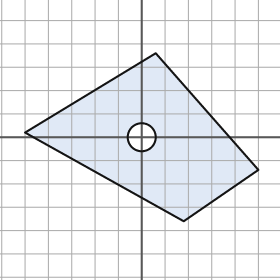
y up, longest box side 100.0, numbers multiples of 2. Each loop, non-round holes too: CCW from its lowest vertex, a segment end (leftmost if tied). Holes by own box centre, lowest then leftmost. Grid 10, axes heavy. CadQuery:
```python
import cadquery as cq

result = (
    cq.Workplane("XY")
    .moveTo(18.0, -36.0)
    .lineTo(50.0, -14.0)
    .lineTo(6.0, 36.0)
    .lineTo(-50.0, 2.0)
    .close()
    .moveTo(0.0, 0.0)
    .circle(6.0)
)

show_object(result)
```